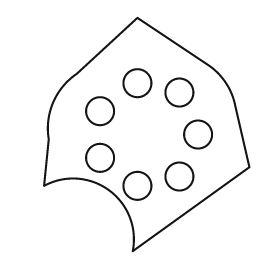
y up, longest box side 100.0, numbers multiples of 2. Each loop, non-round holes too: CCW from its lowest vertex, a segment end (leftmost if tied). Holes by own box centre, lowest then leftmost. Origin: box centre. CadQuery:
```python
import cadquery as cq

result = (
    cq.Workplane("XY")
    .moveTo(-6.0, -50.0)
    .lineTo(44.0, -14.0)
    .lineTo(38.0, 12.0)
    .threePointArc((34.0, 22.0), (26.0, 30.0))
    .lineTo(-4.0, 50.0)
    .lineTo(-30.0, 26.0)
    .threePointArc((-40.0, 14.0), (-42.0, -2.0))
    .lineTo(-44.0, -22.0)
    .threePointArc((-16.0, -24.0), (-6.0, -50.0))
    .close()
    .moveTo(-4.0, -22.0)
    .circle(6.0)
    .moveTo(14.0, -18.0)
    .circle(6.0)
    .moveTo(-20.0, -10.0)
    .circle(6.0)
    .moveTo(22.0, 0.0)
    .circle(6.0)
    .moveTo(-20.0, 10.0)
    .circle(6.0)
    .moveTo(14.0, 18.0)
    .circle(6.0)
    .moveTo(-4.0, 22.0)
    .circle(6.0)
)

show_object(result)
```